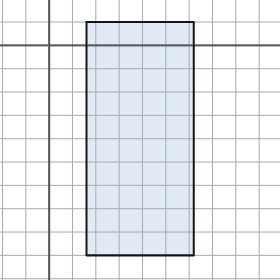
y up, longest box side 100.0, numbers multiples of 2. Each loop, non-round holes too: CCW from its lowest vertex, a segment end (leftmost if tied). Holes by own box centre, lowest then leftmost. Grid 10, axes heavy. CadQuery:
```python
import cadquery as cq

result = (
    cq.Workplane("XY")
    .moveTo(16.0, -90.0)
    .lineTo(62.0, -90.0)
    .lineTo(62.0, 10.0)
    .lineTo(16.0, 10.0)
    .close()
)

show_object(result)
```